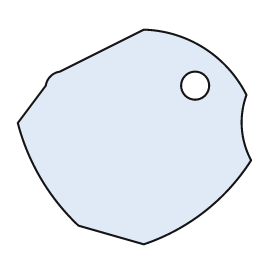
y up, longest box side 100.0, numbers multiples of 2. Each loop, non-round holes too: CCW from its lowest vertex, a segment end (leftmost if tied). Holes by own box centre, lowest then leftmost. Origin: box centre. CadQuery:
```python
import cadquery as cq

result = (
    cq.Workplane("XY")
    .moveTo(4.0, -46.0)
    .threePointArc((30.0, -32.0), (50.0, -10.0))
    .threePointArc((46.0, 4.0), (48.0, 18.0))
    .threePointArc((30.0, 38.0), (4.0, 46.0))
    .lineTo(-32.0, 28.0)
    .threePointArc((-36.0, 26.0), (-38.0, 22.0))
    .lineTo(-50.0, 6.0)
    .threePointArc((-40.0, -18.0), (-24.0, -38.0))
    .close()
    .moveTo(26.0, 22.0)
    .circle(6.0)
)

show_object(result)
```